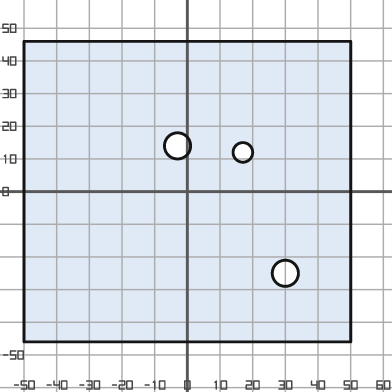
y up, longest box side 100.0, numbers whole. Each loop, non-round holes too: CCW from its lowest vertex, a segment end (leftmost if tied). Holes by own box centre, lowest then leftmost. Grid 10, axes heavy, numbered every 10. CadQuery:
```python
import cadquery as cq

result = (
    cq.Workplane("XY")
    .moveTo(-50.0, -46.0)
    .lineTo(50.0, -46.0)
    .lineTo(50.0, 46.0)
    .lineTo(-50.0, 46.0)
    .close()
    .moveTo(30.0, -25.0)
    .circle(4.0)
    .moveTo(17.0, 12.0)
    .circle(3.0)
    .moveTo(-3.0, 14.0)
    .circle(4.0)
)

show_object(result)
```